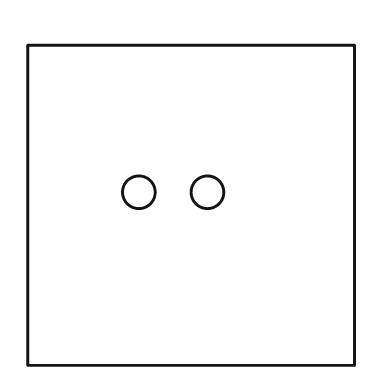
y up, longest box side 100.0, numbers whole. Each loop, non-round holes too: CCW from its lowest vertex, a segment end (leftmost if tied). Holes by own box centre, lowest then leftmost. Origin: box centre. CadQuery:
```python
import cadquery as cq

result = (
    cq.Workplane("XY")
    .moveTo(-50.0, -49.0)
    .lineTo(50.0, -49.0)
    .lineTo(50.0, 49.0)
    .lineTo(-50.0, 49.0)
    .close()
    .moveTo(-16.0, 4.0)
    .circle(5.0)
    .moveTo(5.0, 4.0)
    .circle(5.0)
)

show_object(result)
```